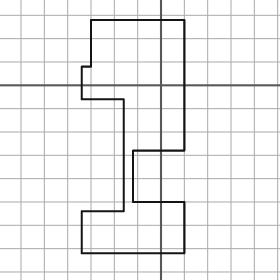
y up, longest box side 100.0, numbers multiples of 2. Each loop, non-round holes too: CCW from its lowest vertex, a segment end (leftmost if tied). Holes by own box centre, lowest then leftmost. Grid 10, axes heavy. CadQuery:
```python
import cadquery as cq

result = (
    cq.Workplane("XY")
    .moveTo(-34.0, -72.0)
    .lineTo(10.0, -72.0)
    .lineTo(10.0, -50.0)
    .lineTo(-12.0, -50.0)
    .lineTo(-12.0, -28.0)
    .lineTo(10.0, -28.0)
    .lineTo(10.0, 28.0)
    .lineTo(-30.0, 28.0)
    .lineTo(-30.0, 8.0)
    .lineTo(-34.0, 8.0)
    .lineTo(-34.0, -6.0)
    .lineTo(-16.0, -6.0)
    .lineTo(-16.0, -54.0)
    .lineTo(-34.0, -54.0)
    .close()
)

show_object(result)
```